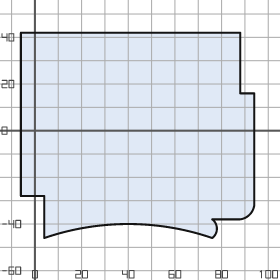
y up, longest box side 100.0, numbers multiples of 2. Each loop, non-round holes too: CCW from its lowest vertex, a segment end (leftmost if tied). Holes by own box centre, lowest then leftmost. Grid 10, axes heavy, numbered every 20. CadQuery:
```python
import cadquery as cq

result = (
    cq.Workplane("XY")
    .moveTo(4.0, -46.0)
    .threePointArc((40.0, -40.0), (76.0, -46.0))
    .threePointArc((78.0, -42.0), (76.0, -38.0))
    .lineTo(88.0, -38.0)
    .threePointArc((92.0, -36.0), (94.0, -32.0))
    .lineTo(94.0, 16.0)
    .lineTo(88.0, 16.0)
    .lineTo(88.0, 42.0)
    .lineTo(-6.0, 42.0)
    .lineTo(-6.0, -28.0)
    .lineTo(4.0, -28.0)
    .close()
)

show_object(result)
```